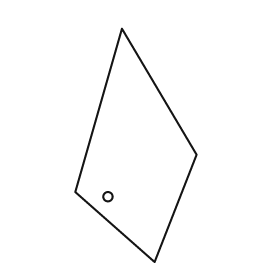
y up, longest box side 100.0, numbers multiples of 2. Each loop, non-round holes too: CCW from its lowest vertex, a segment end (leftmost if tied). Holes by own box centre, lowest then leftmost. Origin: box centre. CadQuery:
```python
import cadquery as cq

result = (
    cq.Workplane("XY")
    .moveTo(8.0, -50.0)
    .lineTo(26.0, -4.0)
    .lineTo(-6.0, 50.0)
    .lineTo(-26.0, -20.0)
    .close()
    .moveTo(-12.0, -22.0)
    .circle(2.0)
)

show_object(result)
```